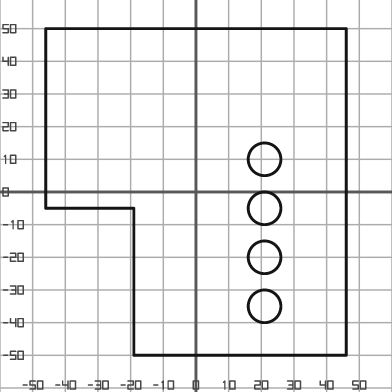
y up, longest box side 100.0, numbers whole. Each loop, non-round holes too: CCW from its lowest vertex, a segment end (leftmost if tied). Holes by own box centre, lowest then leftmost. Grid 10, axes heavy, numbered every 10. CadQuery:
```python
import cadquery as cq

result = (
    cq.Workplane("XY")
    .moveTo(-19.0, -50.0)
    .lineTo(46.0, -50.0)
    .lineTo(46.0, 50.0)
    .lineTo(-46.0, 50.0)
    .lineTo(-46.0, -5.0)
    .lineTo(-19.0, -5.0)
    .close()
    .moveTo(21.0, -35.0)
    .circle(5.0)
    .moveTo(21.0, -20.0)
    .circle(5.0)
    .moveTo(21.0, -5.0)
    .circle(5.0)
    .moveTo(21.0, 10.0)
    .circle(5.0)
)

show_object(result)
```